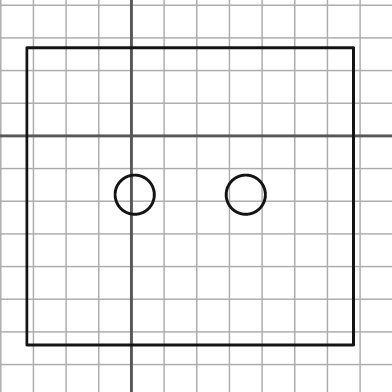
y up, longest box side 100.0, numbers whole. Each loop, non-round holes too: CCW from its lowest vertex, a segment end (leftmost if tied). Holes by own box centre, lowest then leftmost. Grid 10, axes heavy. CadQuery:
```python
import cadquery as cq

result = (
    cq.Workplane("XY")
    .moveTo(-32.0, -64.0)
    .lineTo(68.0, -64.0)
    .lineTo(68.0, 27.0)
    .lineTo(-32.0, 27.0)
    .close()
    .moveTo(1.0, -18.0)
    .circle(6.0)
    .moveTo(35.0, -18.0)
    .circle(6.0)
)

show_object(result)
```